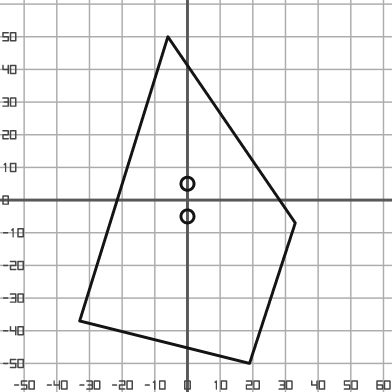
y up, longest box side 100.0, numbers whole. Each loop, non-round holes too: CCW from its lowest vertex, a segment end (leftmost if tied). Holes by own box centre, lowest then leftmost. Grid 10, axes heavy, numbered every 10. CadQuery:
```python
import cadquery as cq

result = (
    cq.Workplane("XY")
    .moveTo(19.0, -50.0)
    .lineTo(33.0, -7.0)
    .lineTo(-6.0, 50.0)
    .lineTo(-33.0, -37.0)
    .close()
    .moveTo(0.0, -5.0)
    .circle(2.0)
    .moveTo(0.0, 5.0)
    .circle(2.0)
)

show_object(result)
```